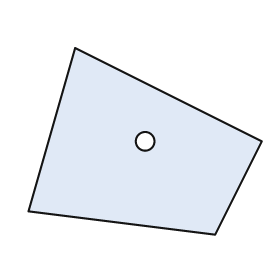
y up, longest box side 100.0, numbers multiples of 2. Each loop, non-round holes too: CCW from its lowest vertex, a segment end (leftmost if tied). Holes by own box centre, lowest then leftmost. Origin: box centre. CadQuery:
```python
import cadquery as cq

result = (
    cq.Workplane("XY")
    .moveTo(30.0, -40.0)
    .lineTo(50.0, 0.0)
    .lineTo(-30.0, 40.0)
    .lineTo(-50.0, -30.0)
    .close()
    .moveTo(0.0, 0.0)
    .circle(4.0)
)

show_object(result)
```